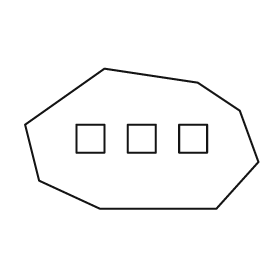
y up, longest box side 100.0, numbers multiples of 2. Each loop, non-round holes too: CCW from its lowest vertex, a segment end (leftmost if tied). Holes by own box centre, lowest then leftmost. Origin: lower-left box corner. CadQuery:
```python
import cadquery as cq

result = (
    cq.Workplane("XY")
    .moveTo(32.0, 0.0)
    .lineTo(82.0, 0.0)
    .lineTo(100.0, 20.0)
    .lineTo(92.0, 42.0)
    .lineTo(74.0, 54.0)
    .lineTo(34.0, 60.0)
    .lineTo(0.0, 36.0)
    .lineTo(6.0, 12.0)
    .close()
    .moveTo(22.0, 24.0)
    .lineTo(34.0, 24.0)
    .lineTo(34.0, 36.0)
    .lineTo(22.0, 36.0)
    .close()
    .moveTo(44.0, 24.0)
    .lineTo(56.0, 24.0)
    .lineTo(56.0, 36.0)
    .lineTo(44.0, 36.0)
    .close()
    .moveTo(66.0, 24.0)
    .lineTo(78.0, 24.0)
    .lineTo(78.0, 36.0)
    .lineTo(66.0, 36.0)
    .close()
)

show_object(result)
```